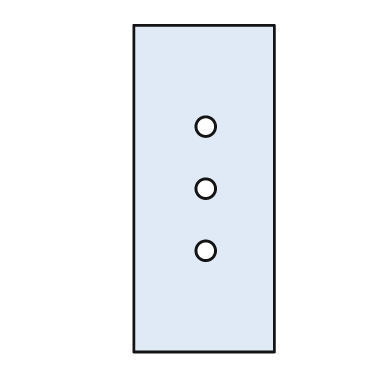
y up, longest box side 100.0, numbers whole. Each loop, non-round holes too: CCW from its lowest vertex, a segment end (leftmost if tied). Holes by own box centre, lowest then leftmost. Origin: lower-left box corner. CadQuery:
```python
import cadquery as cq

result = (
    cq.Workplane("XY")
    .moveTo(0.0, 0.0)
    .lineTo(43.0, 0.0)
    .lineTo(43.0, 100.0)
    .lineTo(0.0, 100.0)
    .close()
    .moveTo(22.0, 31.0)
    .circle(3.0)
    .moveTo(22.0, 50.0)
    .circle(3.0)
    .moveTo(22.0, 69.0)
    .circle(3.0)
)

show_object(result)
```